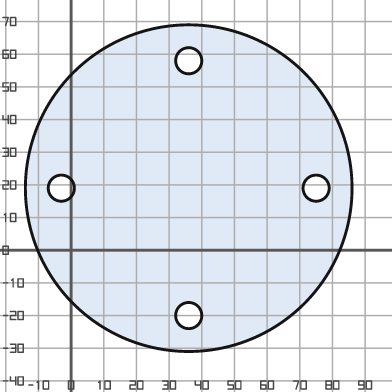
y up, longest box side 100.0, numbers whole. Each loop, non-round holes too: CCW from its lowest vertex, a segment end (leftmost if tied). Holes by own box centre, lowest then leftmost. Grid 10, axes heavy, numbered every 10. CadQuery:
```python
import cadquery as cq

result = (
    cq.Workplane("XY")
    .moveTo(36.0, 19.0)
    .circle(50.0)
    .moveTo(36.0, -20.0)
    .circle(4.0)
    .moveTo(-3.0, 19.0)
    .circle(4.0)
    .moveTo(75.0, 19.0)
    .circle(4.0)
    .moveTo(36.0, 58.0)
    .circle(4.0)
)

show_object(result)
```